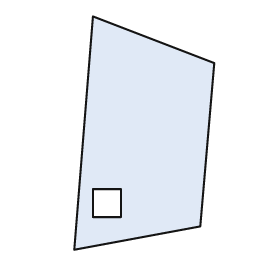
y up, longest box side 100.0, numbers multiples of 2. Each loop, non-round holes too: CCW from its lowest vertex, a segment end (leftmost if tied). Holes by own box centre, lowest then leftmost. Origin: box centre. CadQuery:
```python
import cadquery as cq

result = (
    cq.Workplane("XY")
    .moveTo(-30.0, -50.0)
    .lineTo(24.0, -40.0)
    .lineTo(30.0, 30.0)
    .lineTo(-22.0, 50.0)
    .close()
    .moveTo(-22.0, -36.0)
    .lineTo(-10.0, -36.0)
    .lineTo(-10.0, -24.0)
    .lineTo(-22.0, -24.0)
    .close()
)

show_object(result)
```